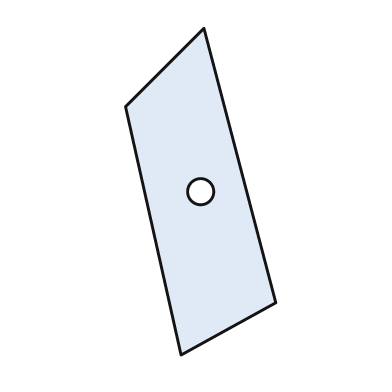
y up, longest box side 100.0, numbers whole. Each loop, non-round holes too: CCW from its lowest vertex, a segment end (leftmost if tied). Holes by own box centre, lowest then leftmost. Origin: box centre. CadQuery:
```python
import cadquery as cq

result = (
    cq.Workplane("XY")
    .moveTo(-6.0, -50.0)
    .lineTo(23.0, -34.0)
    .lineTo(1.0, 50.0)
    .lineTo(-23.0, 26.0)
    .close()
    .moveTo(0.0, 0.0)
    .circle(4.0)
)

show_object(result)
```